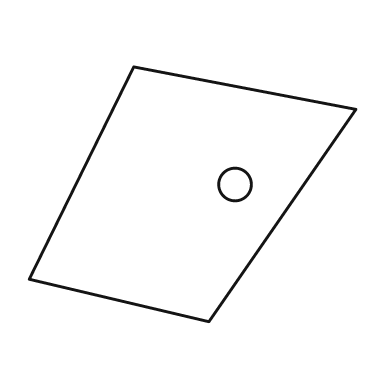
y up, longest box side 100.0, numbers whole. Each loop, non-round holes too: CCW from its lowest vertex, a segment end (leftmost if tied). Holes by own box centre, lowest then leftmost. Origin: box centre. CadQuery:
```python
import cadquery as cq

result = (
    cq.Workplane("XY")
    .moveTo(5.0, -39.0)
    .lineTo(50.0, 26.0)
    .lineTo(-18.0, 39.0)
    .lineTo(-50.0, -26.0)
    .close()
    .moveTo(13.0, 3.0)
    .circle(5.0)
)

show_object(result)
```